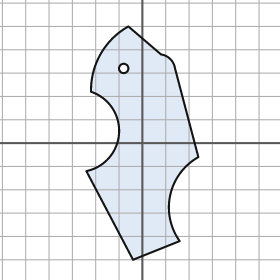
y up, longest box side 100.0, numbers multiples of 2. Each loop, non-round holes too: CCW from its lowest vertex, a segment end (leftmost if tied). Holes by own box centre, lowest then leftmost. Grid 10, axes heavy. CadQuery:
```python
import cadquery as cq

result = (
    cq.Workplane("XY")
    .moveTo(-4.0, -50.0)
    .lineTo(16.0, -42.0)
    .threePointArc((12.0, -22.0), (24.0, -6.0))
    .lineTo(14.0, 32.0)
    .threePointArc((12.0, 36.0), (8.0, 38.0))
    .lineTo(-6.0, 50.0)
    .threePointArc((-18.0, 38.0), (-22.0, 22.0))
    .threePointArc((-10.0, 4.0), (-24.0, -12.0))
    .close()
    .moveTo(-8.0, 32.0)
    .circle(2.0)
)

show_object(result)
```